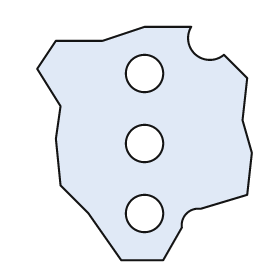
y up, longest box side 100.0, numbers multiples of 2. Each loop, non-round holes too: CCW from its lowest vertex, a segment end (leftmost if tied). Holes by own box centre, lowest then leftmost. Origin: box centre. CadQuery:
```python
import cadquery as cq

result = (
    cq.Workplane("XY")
    .moveTo(-10.0, -50.0)
    .lineTo(8.0, -50.0)
    .lineTo(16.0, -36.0)
    .threePointArc((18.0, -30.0), (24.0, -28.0))
    .lineTo(44.0, -22.0)
    .lineTo(46.0, -4.0)
    .lineTo(42.0, 10.0)
    .lineTo(44.0, 28.0)
    .lineTo(34.0, 38.0)
    .threePointArc((22.0, 38.0), (20.0, 50.0))
    .lineTo(0.0, 50.0)
    .lineTo(-18.0, 44.0)
    .lineTo(-38.0, 44.0)
    .lineTo(-46.0, 32.0)
    .lineTo(-36.0, 16.0)
    .lineTo(-38.0, 2.0)
    .lineTo(-36.0, -18.0)
    .lineTo(-24.0, -30.0)
    .close()
    .moveTo(0.0, -30.0)
    .circle(8.0)
    .moveTo(0.0, 0.0)
    .circle(8.0)
    .moveTo(0.0, 30.0)
    .circle(8.0)
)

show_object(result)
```